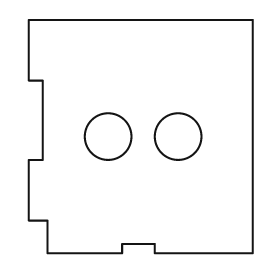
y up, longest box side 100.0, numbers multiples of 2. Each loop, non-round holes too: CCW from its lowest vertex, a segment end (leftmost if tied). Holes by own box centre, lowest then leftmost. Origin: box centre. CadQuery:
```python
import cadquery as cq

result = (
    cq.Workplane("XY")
    .moveTo(-40.0, -50.0)
    .lineTo(-8.0, -50.0)
    .lineTo(-8.0, -46.0)
    .lineTo(6.0, -46.0)
    .lineTo(6.0, -50.0)
    .lineTo(48.0, -50.0)
    .lineTo(48.0, 50.0)
    .lineTo(-48.0, 50.0)
    .lineTo(-48.0, 24.0)
    .lineTo(-42.0, 24.0)
    .lineTo(-42.0, -10.0)
    .lineTo(-48.0, -10.0)
    .lineTo(-48.0, -36.0)
    .lineTo(-40.0, -36.0)
    .close()
    .moveTo(-14.0, 0.0)
    .circle(10.0)
    .moveTo(16.0, 0.0)
    .circle(10.0)
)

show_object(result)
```